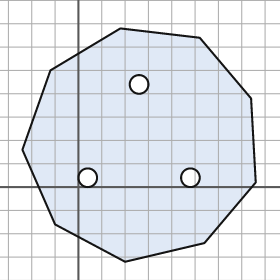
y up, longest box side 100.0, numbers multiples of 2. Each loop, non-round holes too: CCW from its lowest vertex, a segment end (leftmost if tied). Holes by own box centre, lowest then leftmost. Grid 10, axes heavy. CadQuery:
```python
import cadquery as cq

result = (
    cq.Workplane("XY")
    .moveTo(20.0, -32.0)
    .lineTo(54.0, -24.0)
    .lineTo(76.0, 2.0)
    .lineTo(74.0, 38.0)
    .lineTo(52.0, 64.0)
    .lineTo(18.0, 68.0)
    .lineTo(-12.0, 50.0)
    .lineTo(-24.0, 16.0)
    .lineTo(-10.0, -16.0)
    .close()
    .moveTo(4.0, 4.0)
    .circle(4.0)
    .moveTo(48.0, 4.0)
    .circle(4.0)
    .moveTo(26.0, 44.0)
    .circle(4.0)
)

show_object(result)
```